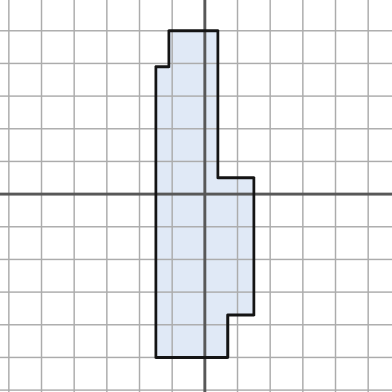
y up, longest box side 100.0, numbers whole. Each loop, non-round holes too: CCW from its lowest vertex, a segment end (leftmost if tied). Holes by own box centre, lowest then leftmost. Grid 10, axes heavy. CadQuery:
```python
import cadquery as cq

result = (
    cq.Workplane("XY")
    .moveTo(-15.0, -50.0)
    .lineTo(7.0, -50.0)
    .lineTo(7.0, -37.0)
    .lineTo(15.0, -37.0)
    .lineTo(15.0, 5.0)
    .lineTo(4.0, 5.0)
    .lineTo(4.0, 50.0)
    .lineTo(-11.0, 50.0)
    .lineTo(-11.0, 39.0)
    .lineTo(-15.0, 39.0)
    .close()
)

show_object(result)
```